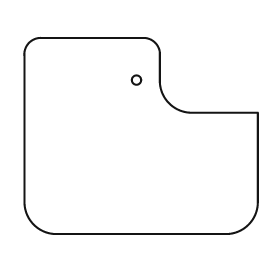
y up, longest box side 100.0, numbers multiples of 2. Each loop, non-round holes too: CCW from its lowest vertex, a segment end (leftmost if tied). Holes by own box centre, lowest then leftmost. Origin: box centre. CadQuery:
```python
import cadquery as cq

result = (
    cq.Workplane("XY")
    .moveTo(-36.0, -42.0)
    .lineTo(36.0, -42.0)
    .threePointArc((46.0, -38.0), (50.0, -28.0))
    .lineTo(50.0, 10.0)
    .lineTo(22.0, 10.0)
    .threePointArc((12.0, 14.0), (8.0, 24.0))
    .lineTo(8.0, 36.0)
    .threePointArc((6.0, 40.0), (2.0, 42.0))
    .lineTo(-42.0, 42.0)
    .threePointArc((-48.0, 40.0), (-50.0, 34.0))
    .lineTo(-50.0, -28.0)
    .threePointArc((-46.0, -38.0), (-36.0, -42.0))
    .close()
    .moveTo(-2.0, 24.0)
    .circle(2.0)
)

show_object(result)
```